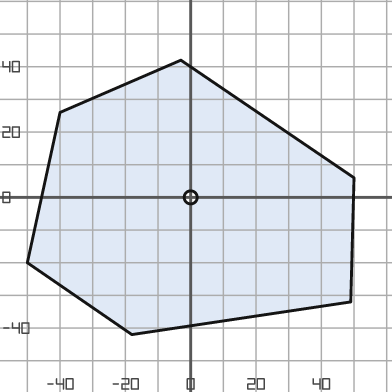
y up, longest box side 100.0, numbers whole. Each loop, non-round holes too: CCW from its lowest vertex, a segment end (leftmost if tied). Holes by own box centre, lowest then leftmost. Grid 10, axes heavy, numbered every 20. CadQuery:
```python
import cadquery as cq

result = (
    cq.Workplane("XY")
    .moveTo(-18.0, -42.0)
    .lineTo(49.0, -32.0)
    .lineTo(50.0, 6.0)
    .lineTo(-3.0, 42.0)
    .lineTo(-40.0, 26.0)
    .lineTo(-50.0, -20.0)
    .close()
    .moveTo(0.0, 0.0)
    .circle(2.0)
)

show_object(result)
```